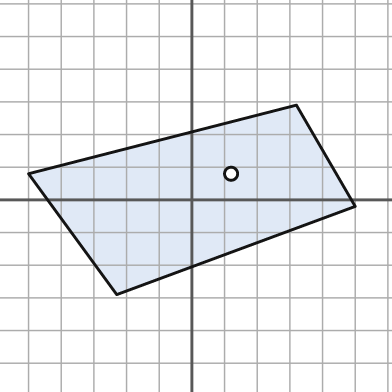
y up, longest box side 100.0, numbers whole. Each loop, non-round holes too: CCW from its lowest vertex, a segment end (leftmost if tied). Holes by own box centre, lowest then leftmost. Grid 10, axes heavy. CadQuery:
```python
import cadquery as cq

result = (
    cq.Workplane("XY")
    .moveTo(-23.0, -29.0)
    .lineTo(50.0, -2.0)
    .lineTo(32.0, 29.0)
    .lineTo(-50.0, 8.0)
    .close()
    .moveTo(12.0, 8.0)
    .circle(2.0)
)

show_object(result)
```